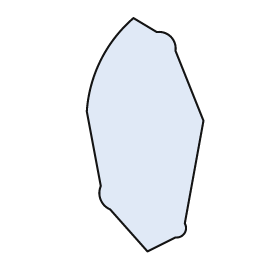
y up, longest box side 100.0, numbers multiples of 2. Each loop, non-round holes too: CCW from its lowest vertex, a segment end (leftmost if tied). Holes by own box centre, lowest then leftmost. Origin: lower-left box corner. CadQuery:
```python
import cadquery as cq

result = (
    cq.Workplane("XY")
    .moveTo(26.0, 0.0)
    .lineTo(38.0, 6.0)
    .threePointArc((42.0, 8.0), (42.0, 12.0))
    .lineTo(50.0, 56.0)
    .lineTo(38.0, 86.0)
    .threePointArc((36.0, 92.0), (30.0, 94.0))
    .lineTo(20.0, 100.0)
    .threePointArc((6.0, 82.0), (0.0, 60.0))
    .lineTo(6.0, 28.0)
    .threePointArc((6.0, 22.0), (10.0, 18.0))
    .close()
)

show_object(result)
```